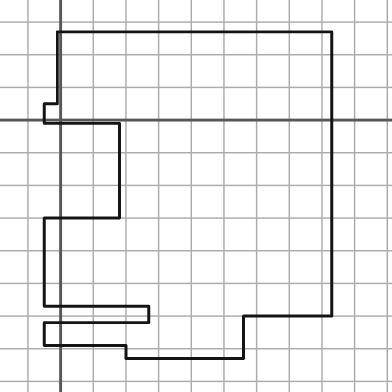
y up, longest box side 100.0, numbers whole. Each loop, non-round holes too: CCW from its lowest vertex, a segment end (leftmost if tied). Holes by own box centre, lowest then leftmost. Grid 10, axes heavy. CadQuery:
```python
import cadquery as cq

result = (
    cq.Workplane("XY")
    .moveTo(20.0, -73.0)
    .lineTo(56.0, -73.0)
    .lineTo(56.0, -60.0)
    .lineTo(83.0, -60.0)
    .lineTo(83.0, 27.0)
    .lineTo(-1.0, 27.0)
    .lineTo(-1.0, 5.0)
    .lineTo(-5.0, 5.0)
    .lineTo(-5.0, -1.0)
    .lineTo(18.0, -1.0)
    .lineTo(18.0, -30.0)
    .lineTo(-5.0, -30.0)
    .lineTo(-5.0, -57.0)
    .lineTo(27.0, -57.0)
    .lineTo(27.0, -62.0)
    .lineTo(-5.0, -62.0)
    .lineTo(-5.0, -69.0)
    .lineTo(20.0, -69.0)
    .close()
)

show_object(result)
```